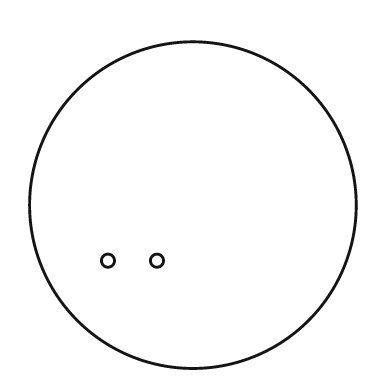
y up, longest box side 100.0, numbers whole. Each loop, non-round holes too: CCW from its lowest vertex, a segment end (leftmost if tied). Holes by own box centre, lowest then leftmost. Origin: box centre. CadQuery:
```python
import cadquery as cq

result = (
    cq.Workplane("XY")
    .moveTo(0.0, 0.0)
    .circle(50.0)
    .moveTo(-26.0, -17.0)
    .circle(2.0)
    .moveTo(-11.0, -17.0)
    .circle(2.0)
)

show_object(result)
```